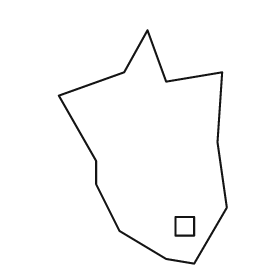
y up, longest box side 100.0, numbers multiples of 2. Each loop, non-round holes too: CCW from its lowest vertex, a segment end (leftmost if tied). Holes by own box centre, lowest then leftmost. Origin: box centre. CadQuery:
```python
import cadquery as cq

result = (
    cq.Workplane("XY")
    .moveTo(22.0, -50.0)
    .lineTo(36.0, -26.0)
    .lineTo(32.0, 2.0)
    .lineTo(34.0, 32.0)
    .lineTo(10.0, 28.0)
    .lineTo(2.0, 50.0)
    .lineTo(-8.0, 32.0)
    .lineTo(-36.0, 22.0)
    .lineTo(-20.0, -6.0)
    .lineTo(-20.0, -16.0)
    .lineTo(-10.0, -36.0)
    .lineTo(10.0, -48.0)
    .close()
    .moveTo(14.0, -38.0)
    .lineTo(22.0, -38.0)
    .lineTo(22.0, -30.0)
    .lineTo(14.0, -30.0)
    .close()
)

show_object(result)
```